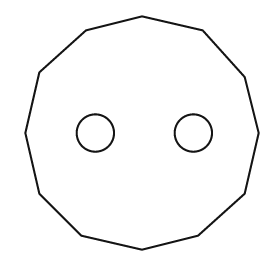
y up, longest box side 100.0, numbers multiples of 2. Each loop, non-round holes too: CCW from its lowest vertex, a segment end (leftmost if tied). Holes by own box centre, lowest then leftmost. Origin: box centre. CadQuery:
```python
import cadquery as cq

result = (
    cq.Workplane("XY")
    .moveTo(0.0, -50.0)
    .lineTo(24.0, -44.0)
    .lineTo(44.0, -26.0)
    .lineTo(50.0, 0.0)
    .lineTo(44.0, 24.0)
    .lineTo(26.0, 44.0)
    .lineTo(0.0, 50.0)
    .lineTo(-24.0, 44.0)
    .lineTo(-44.0, 26.0)
    .lineTo(-50.0, 0.0)
    .lineTo(-44.0, -26.0)
    .lineTo(-26.0, -44.0)
    .close()
    .moveTo(-20.0, 0.0)
    .circle(8.0)
    .moveTo(22.0, 0.0)
    .circle(8.0)
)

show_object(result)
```